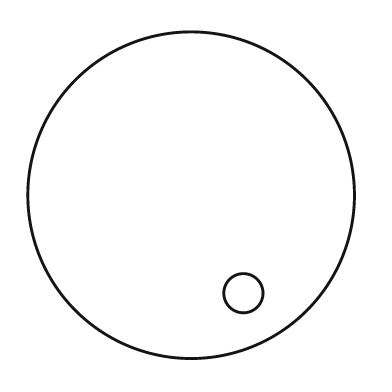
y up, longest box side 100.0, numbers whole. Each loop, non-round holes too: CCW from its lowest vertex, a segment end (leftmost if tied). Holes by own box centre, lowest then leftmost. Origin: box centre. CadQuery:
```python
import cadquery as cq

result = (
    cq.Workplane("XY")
    .moveTo(0.0, 0.0)
    .circle(50.0)
    .moveTo(16.0, -30.0)
    .circle(6.0)
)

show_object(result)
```